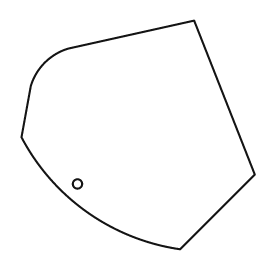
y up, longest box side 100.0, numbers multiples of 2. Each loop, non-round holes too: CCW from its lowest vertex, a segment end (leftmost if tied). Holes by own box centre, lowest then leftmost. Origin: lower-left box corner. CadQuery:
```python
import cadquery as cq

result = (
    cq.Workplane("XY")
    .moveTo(68.0, 0.0)
    .lineTo(100.0, 32.0)
    .lineTo(74.0, 98.0)
    .lineTo(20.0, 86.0)
    .threePointArc((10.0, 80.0), (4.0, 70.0))
    .lineTo(0.0, 48.0)
    .threePointArc((28.0, 16.0), (68.0, 0.0))
    .close()
    .moveTo(24.0, 28.0)
    .circle(2.0)
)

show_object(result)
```